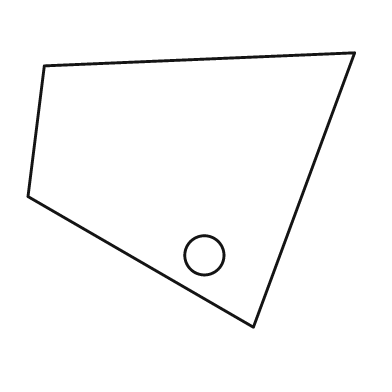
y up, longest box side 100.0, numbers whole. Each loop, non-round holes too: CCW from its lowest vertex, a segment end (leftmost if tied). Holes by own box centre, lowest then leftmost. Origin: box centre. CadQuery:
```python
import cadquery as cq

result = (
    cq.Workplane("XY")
    .moveTo(19.0, -42.0)
    .lineTo(50.0, 42.0)
    .lineTo(-45.0, 38.0)
    .lineTo(-50.0, -2.0)
    .close()
    .moveTo(4.0, -20.0)
    .circle(6.0)
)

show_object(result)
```